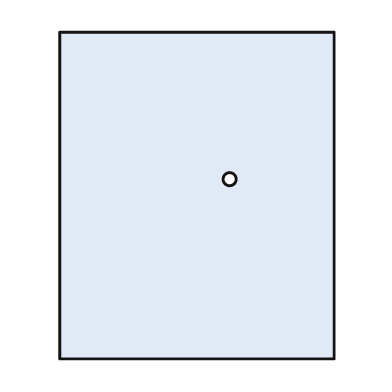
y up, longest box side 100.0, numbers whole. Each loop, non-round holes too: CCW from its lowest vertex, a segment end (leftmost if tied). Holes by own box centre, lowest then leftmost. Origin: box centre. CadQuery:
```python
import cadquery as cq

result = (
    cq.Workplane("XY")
    .moveTo(-42.0, -50.0)
    .lineTo(42.0, -50.0)
    .lineTo(42.0, 50.0)
    .lineTo(-42.0, 50.0)
    .close()
    .moveTo(10.0, 5.0)
    .circle(2.0)
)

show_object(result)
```